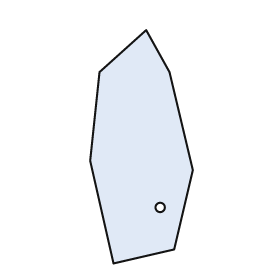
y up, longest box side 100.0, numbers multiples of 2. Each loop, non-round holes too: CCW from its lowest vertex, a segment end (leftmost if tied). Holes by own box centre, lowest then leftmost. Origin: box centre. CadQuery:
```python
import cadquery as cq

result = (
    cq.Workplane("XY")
    .moveTo(-12.0, -50.0)
    .lineTo(14.0, -44.0)
    .lineTo(22.0, -10.0)
    .lineTo(12.0, 32.0)
    .lineTo(2.0, 50.0)
    .lineTo(-18.0, 32.0)
    .lineTo(-22.0, -6.0)
    .close()
    .moveTo(8.0, -26.0)
    .circle(2.0)
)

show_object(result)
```